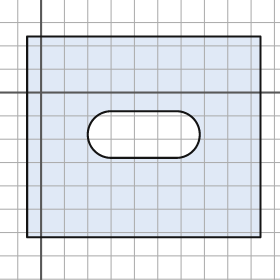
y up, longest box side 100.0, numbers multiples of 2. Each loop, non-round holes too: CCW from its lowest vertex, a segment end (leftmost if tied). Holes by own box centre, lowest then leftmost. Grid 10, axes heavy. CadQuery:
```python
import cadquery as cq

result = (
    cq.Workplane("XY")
    .moveTo(-6.0, -62.0)
    .lineTo(94.0, -62.0)
    .lineTo(94.0, 24.0)
    .lineTo(-6.0, 24.0)
    .close()
    .moveTo(30.0, -28.0)
    .lineTo(58.0, -28.0)
    .threePointArc((68.0, -18.0), (58.0, -8.0))
    .lineTo(30.0, -8.0)
    .threePointArc((20.0, -18.0), (30.0, -28.0))
    .close()
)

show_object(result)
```